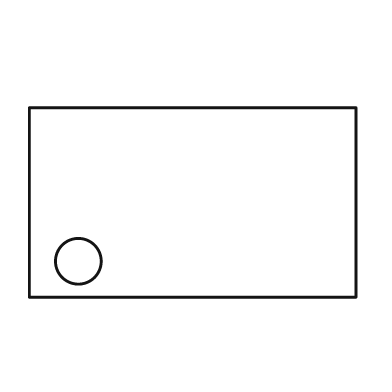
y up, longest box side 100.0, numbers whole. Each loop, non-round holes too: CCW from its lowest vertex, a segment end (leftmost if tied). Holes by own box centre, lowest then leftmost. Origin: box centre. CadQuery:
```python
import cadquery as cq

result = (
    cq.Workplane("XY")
    .moveTo(-50.0, -29.0)
    .lineTo(50.0, -29.0)
    .lineTo(50.0, 29.0)
    .lineTo(-50.0, 29.0)
    .close()
    .moveTo(-35.0, -18.0)
    .circle(7.0)
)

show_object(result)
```